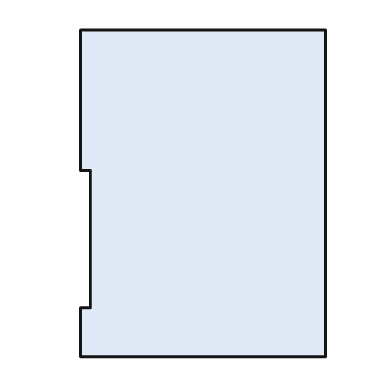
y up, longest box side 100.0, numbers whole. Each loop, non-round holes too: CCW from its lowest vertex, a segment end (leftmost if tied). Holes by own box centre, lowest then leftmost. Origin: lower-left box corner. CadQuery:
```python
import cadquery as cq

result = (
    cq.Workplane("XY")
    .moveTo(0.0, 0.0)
    .lineTo(75.0, 0.0)
    .lineTo(75.0, 100.0)
    .lineTo(0.0, 100.0)
    .lineTo(0.0, 57.0)
    .lineTo(3.0, 57.0)
    .lineTo(3.0, 15.0)
    .lineTo(0.0, 15.0)
    .close()
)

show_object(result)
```